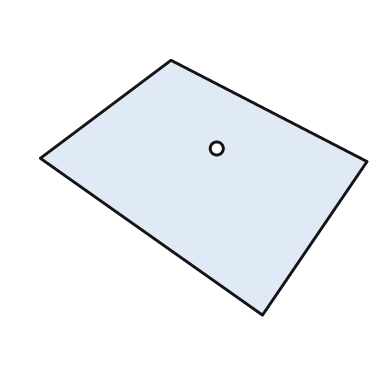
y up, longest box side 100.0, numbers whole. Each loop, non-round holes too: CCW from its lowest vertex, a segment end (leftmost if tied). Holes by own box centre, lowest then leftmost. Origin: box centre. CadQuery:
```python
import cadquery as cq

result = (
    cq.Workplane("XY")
    .moveTo(18.0, -39.0)
    .lineTo(50.0, 8.0)
    .lineTo(-10.0, 39.0)
    .lineTo(-50.0, 9.0)
    .close()
    .moveTo(4.0, 12.0)
    .circle(2.0)
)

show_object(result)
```